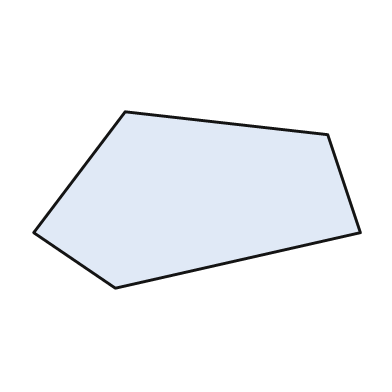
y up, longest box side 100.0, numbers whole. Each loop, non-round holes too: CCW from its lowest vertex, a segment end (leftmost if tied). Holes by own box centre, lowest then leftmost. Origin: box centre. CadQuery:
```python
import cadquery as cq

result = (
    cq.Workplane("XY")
    .moveTo(-25.0, -27.0)
    .lineTo(50.0, -10.0)
    .lineTo(40.0, 20.0)
    .lineTo(-22.0, 27.0)
    .lineTo(-50.0, -10.0)
    .close()
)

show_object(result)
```